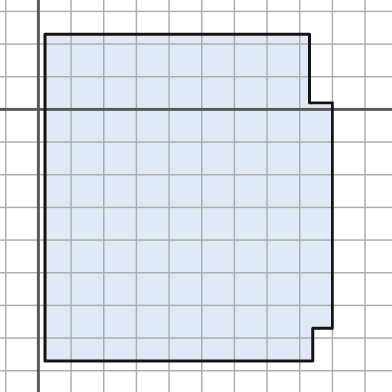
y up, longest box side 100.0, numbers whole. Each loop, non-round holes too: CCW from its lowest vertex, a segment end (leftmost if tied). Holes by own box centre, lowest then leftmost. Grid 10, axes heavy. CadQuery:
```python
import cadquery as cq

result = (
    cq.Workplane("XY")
    .moveTo(2.0, -77.0)
    .lineTo(84.0, -77.0)
    .lineTo(84.0, -67.0)
    .lineTo(90.0, -67.0)
    .lineTo(90.0, 2.0)
    .lineTo(83.0, 2.0)
    .lineTo(83.0, 23.0)
    .lineTo(2.0, 23.0)
    .close()
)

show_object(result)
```